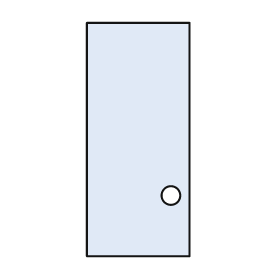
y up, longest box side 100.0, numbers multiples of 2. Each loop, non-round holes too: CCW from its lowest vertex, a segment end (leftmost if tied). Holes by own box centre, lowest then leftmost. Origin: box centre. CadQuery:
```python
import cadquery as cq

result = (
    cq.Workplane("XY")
    .moveTo(-22.0, -50.0)
    .lineTo(22.0, -50.0)
    .lineTo(22.0, 50.0)
    .lineTo(-22.0, 50.0)
    .close()
    .moveTo(14.0, -24.0)
    .circle(4.0)
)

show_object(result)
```